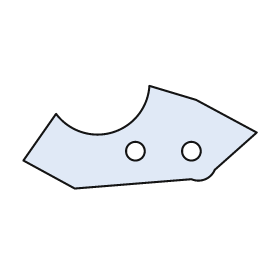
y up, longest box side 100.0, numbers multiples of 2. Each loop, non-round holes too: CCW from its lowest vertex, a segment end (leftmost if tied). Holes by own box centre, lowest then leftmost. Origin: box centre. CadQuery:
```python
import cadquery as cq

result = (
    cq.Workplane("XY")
    .moveTo(-28.0, -22.0)
    .lineTo(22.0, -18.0)
    .threePointArc((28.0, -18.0), (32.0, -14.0))
    .lineTo(50.0, 2.0)
    .lineTo(24.0, 16.0)
    .lineTo(4.0, 22.0)
    .threePointArc((-12.0, 2.0), (-36.0, 10.0))
    .lineTo(-50.0, -10.0)
    .close()
    .moveTo(-2.0, -6.0)
    .circle(4.0)
    .moveTo(22.0, -6.0)
    .circle(4.0)
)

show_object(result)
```